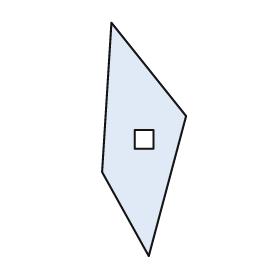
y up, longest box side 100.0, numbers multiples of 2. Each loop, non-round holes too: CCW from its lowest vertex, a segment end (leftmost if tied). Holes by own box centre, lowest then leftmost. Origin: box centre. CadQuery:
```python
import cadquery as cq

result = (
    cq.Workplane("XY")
    .moveTo(2.0, -50.0)
    .lineTo(18.0, 10.0)
    .lineTo(-14.0, 50.0)
    .lineTo(-18.0, -14.0)
    .close()
    .moveTo(-4.0, -4.0)
    .lineTo(4.0, -4.0)
    .lineTo(4.0, 4.0)
    .lineTo(-4.0, 4.0)
    .close()
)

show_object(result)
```